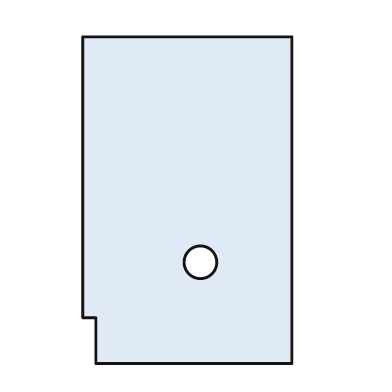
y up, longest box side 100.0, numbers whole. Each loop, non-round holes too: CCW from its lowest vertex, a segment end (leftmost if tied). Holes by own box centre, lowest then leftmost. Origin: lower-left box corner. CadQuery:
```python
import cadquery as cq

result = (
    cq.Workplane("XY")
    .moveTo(4.0, 0.0)
    .lineTo(64.0, 0.0)
    .lineTo(64.0, 100.0)
    .lineTo(0.0, 100.0)
    .lineTo(0.0, 14.0)
    .lineTo(4.0, 14.0)
    .close()
    .moveTo(36.0, 31.0)
    .circle(5.0)
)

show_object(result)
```